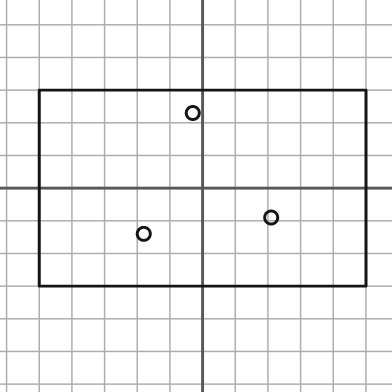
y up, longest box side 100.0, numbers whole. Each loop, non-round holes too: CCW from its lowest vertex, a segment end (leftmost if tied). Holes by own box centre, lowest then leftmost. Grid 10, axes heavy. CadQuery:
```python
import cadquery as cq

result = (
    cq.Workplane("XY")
    .moveTo(-50.0, -30.0)
    .lineTo(50.0, -30.0)
    .lineTo(50.0, 30.0)
    .lineTo(-50.0, 30.0)
    .close()
    .moveTo(-18.0, -14.0)
    .circle(2.0)
    .moveTo(21.0, -9.0)
    .circle(2.0)
    .moveTo(-3.0, 23.0)
    .circle(2.0)
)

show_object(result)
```